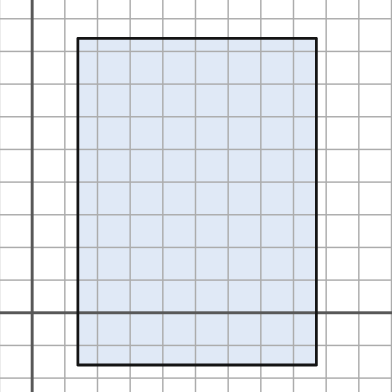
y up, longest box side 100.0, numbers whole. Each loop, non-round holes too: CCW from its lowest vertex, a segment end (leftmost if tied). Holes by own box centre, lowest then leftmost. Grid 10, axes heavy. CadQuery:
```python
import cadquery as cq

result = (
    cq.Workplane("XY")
    .moveTo(14.0, -16.0)
    .lineTo(87.0, -16.0)
    .lineTo(87.0, 84.0)
    .lineTo(14.0, 84.0)
    .close()
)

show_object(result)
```